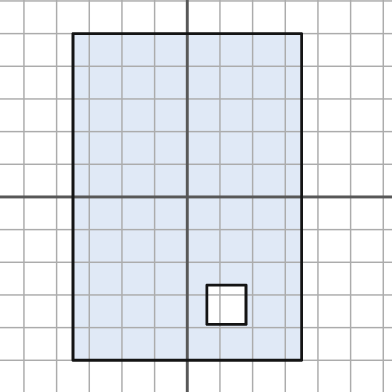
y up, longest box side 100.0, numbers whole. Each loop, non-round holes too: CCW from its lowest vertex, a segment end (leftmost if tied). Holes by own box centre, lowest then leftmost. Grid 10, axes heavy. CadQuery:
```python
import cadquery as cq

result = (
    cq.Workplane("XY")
    .moveTo(-35.0, -50.0)
    .lineTo(35.0, -50.0)
    .lineTo(35.0, 50.0)
    .lineTo(-35.0, 50.0)
    .close()
    .moveTo(6.0, -39.0)
    .lineTo(18.0, -39.0)
    .lineTo(18.0, -27.0)
    .lineTo(6.0, -27.0)
    .close()
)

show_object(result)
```